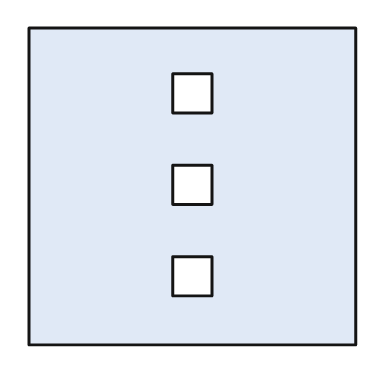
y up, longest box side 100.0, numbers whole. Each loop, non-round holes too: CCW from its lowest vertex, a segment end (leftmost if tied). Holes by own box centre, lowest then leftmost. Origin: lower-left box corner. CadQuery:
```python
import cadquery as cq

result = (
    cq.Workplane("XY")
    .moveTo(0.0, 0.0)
    .lineTo(100.0, 0.0)
    .lineTo(100.0, 97.0)
    .lineTo(0.0, 97.0)
    .close()
    .moveTo(44.0, 15.0)
    .lineTo(56.0, 15.0)
    .lineTo(56.0, 27.0)
    .lineTo(44.0, 27.0)
    .close()
    .moveTo(44.0, 43.0)
    .lineTo(56.0, 43.0)
    .lineTo(56.0, 55.0)
    .lineTo(44.0, 55.0)
    .close()
    .moveTo(44.0, 71.0)
    .lineTo(56.0, 71.0)
    .lineTo(56.0, 83.0)
    .lineTo(44.0, 83.0)
    .close()
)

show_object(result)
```